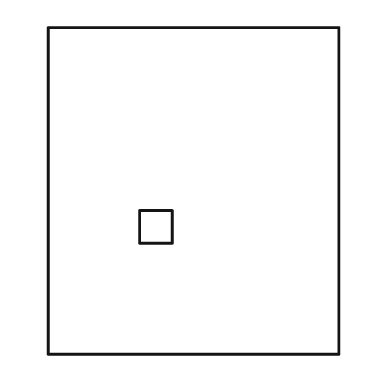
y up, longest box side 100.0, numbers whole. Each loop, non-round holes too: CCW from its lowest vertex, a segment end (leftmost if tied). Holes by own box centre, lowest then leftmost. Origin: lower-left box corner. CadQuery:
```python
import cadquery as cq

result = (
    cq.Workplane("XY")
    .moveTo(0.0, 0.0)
    .lineTo(89.0, 0.0)
    .lineTo(89.0, 100.0)
    .lineTo(0.0, 100.0)
    .close()
    .moveTo(28.0, 34.0)
    .lineTo(38.0, 34.0)
    .lineTo(38.0, 44.0)
    .lineTo(28.0, 44.0)
    .close()
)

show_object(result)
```